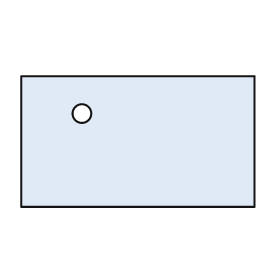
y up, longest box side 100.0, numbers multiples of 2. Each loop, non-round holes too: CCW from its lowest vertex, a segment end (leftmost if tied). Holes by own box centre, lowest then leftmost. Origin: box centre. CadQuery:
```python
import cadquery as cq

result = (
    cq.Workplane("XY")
    .moveTo(-50.0, -28.0)
    .lineTo(50.0, -28.0)
    .lineTo(50.0, 28.0)
    .lineTo(-50.0, 28.0)
    .close()
    .moveTo(-24.0, 12.0)
    .circle(4.0)
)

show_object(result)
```